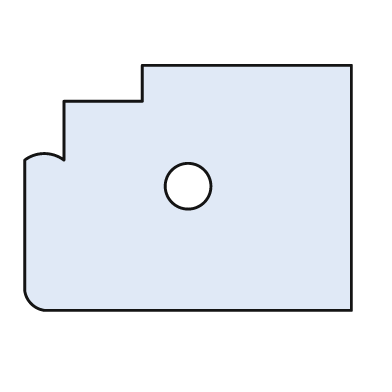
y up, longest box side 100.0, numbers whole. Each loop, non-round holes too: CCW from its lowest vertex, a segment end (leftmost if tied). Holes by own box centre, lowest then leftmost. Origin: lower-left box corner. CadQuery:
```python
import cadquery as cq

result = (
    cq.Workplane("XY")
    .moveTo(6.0, 0.0)
    .lineTo(100.0, 0.0)
    .lineTo(100.0, 75.0)
    .lineTo(36.0, 75.0)
    .lineTo(36.0, 64.0)
    .lineTo(12.0, 64.0)
    .lineTo(12.0, 46.0)
    .threePointArc((6.0, 48.0), (0.0, 46.0))
    .lineTo(0.0, 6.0)
    .threePointArc((2.0, 2.0), (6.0, 0.0))
    .close()
    .moveTo(50.0, 38.0)
    .circle(7.0)
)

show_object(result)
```